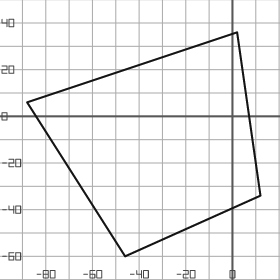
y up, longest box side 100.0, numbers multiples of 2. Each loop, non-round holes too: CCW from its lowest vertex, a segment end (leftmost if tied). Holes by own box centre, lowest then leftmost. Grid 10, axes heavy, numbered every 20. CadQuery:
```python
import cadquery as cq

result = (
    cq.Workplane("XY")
    .moveTo(-46.0, -60.0)
    .lineTo(12.0, -34.0)
    .lineTo(2.0, 36.0)
    .lineTo(-88.0, 6.0)
    .close()
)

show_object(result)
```